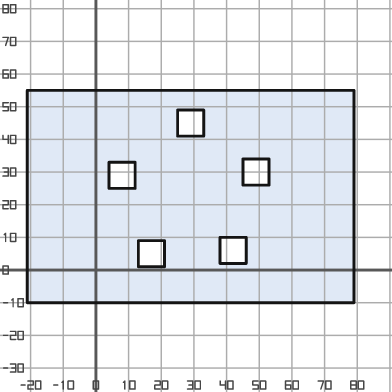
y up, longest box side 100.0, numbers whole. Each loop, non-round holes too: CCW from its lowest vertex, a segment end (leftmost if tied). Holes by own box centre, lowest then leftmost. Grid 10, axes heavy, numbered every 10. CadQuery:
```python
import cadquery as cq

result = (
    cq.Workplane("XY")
    .moveTo(-21.0, -10.0)
    .lineTo(79.0, -10.0)
    .lineTo(79.0, 55.0)
    .lineTo(-21.0, 55.0)
    .close()
    .moveTo(13.0, 1.0)
    .lineTo(21.0, 1.0)
    .lineTo(21.0, 9.0)
    .lineTo(13.0, 9.0)
    .close()
    .moveTo(38.0, 2.0)
    .lineTo(46.0, 2.0)
    .lineTo(46.0, 10.0)
    .lineTo(38.0, 10.0)
    .close()
    .moveTo(4.0, 25.0)
    .lineTo(12.0, 25.0)
    .lineTo(12.0, 33.0)
    .lineTo(4.0, 33.0)
    .close()
    .moveTo(45.0, 26.0)
    .lineTo(53.0, 26.0)
    .lineTo(53.0, 34.0)
    .lineTo(45.0, 34.0)
    .close()
    .moveTo(25.0, 41.0)
    .lineTo(33.0, 41.0)
    .lineTo(33.0, 49.0)
    .lineTo(25.0, 49.0)
    .close()
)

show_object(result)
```